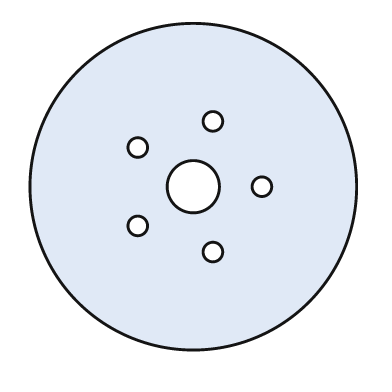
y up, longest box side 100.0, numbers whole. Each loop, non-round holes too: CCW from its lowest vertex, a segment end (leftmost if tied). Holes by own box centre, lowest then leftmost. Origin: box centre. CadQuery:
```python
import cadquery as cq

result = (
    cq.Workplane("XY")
    .moveTo(0.0, 0.0)
    .circle(50.0)
    .moveTo(6.0, -20.0)
    .circle(3.0)
    .moveTo(-17.0, -12.0)
    .circle(3.0)
    .moveTo(0.0, 0.0)
    .circle(8.0)
    .moveTo(21.0, 0.0)
    .circle(3.0)
    .moveTo(-17.0, 12.0)
    .circle(3.0)
    .moveTo(6.0, 20.0)
    .circle(3.0)
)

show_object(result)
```